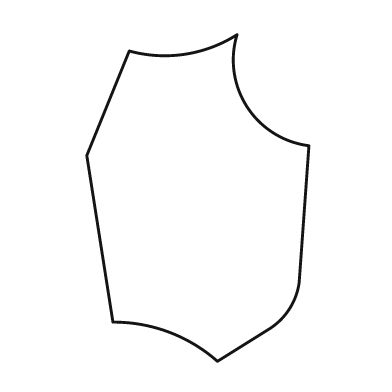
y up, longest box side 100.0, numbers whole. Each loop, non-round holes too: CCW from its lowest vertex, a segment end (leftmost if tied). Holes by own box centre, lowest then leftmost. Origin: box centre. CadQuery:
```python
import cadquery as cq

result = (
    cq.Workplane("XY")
    .moveTo(6.0, -50.0)
    .lineTo(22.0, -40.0)
    .threePointArc((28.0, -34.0), (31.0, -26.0))
    .lineTo(34.0, 16.0)
    .threePointArc((15.0, 28.0), (12.0, 50.0))
    .threePointArc((-4.0, 44.0), (-21.0, 45.0))
    .lineTo(-34.0, 13.0)
    .lineTo(-26.0, -38.0)
    .threePointArc((-9.0, -41.0), (6.0, -50.0))
    .close()
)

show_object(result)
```